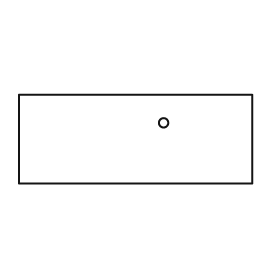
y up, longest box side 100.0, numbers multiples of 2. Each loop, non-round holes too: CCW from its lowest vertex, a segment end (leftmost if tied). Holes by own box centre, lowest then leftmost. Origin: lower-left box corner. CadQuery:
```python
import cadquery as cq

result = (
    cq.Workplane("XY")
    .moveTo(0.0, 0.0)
    .lineTo(100.0, 0.0)
    .lineTo(100.0, 38.0)
    .lineTo(0.0, 38.0)
    .close()
    .moveTo(62.0, 26.0)
    .circle(2.0)
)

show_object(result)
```